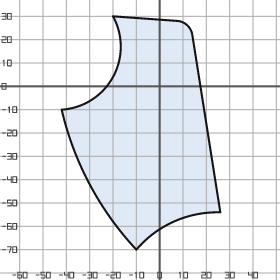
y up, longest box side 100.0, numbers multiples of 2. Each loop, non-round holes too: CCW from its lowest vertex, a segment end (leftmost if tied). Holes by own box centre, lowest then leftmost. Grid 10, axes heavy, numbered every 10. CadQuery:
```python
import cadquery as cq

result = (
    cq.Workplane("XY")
    .moveTo(-10.0, -70.0)
    .threePointArc((6.0, -58.0), (26.0, -54.0))
    .lineTo(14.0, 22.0)
    .threePointArc((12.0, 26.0), (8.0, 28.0))
    .lineTo(-20.0, 30.0)
    .threePointArc((-20.0, 4.0), (-42.0, -10.0))
    .threePointArc((-30.0, -42.0), (-10.0, -70.0))
    .close()
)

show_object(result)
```